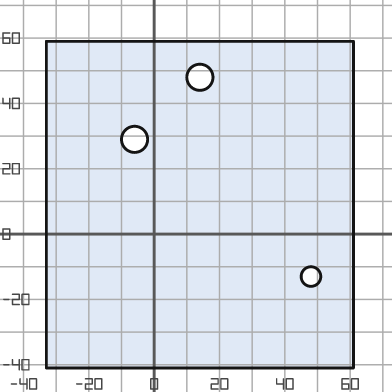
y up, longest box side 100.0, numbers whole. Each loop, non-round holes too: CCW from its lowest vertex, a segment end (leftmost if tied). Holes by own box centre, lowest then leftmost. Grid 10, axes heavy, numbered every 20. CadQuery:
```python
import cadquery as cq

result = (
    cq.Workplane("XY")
    .moveTo(-33.0, -41.0)
    .lineTo(61.0, -41.0)
    .lineTo(61.0, 59.0)
    .lineTo(-33.0, 59.0)
    .close()
    .moveTo(48.0, -13.0)
    .circle(3.0)
    .moveTo(-6.0, 29.0)
    .circle(4.0)
    .moveTo(14.0, 48.0)
    .circle(4.0)
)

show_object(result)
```